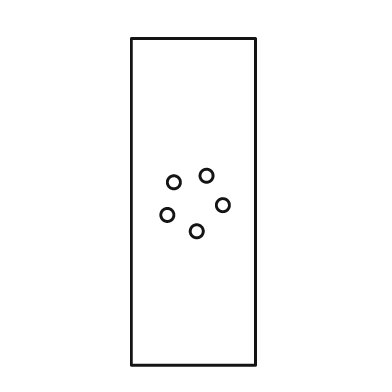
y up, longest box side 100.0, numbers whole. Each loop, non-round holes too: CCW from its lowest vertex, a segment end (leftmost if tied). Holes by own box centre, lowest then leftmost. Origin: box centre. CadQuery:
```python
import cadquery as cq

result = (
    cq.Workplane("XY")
    .moveTo(-19.0, -50.0)
    .lineTo(19.0, -50.0)
    .lineTo(19.0, 50.0)
    .lineTo(-19.0, 50.0)
    .close()
    .moveTo(1.0, -9.0)
    .circle(2.0)
    .moveTo(-8.0, -4.0)
    .circle(2.0)
    .moveTo(9.0, -1.0)
    .circle(2.0)
    .moveTo(-6.0, 6.0)
    .circle(2.0)
    .moveTo(4.0, 8.0)
    .circle(2.0)
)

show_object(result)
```